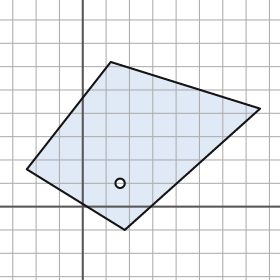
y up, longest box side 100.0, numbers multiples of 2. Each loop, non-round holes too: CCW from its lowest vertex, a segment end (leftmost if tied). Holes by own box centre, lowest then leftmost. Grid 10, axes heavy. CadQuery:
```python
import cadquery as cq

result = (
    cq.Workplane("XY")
    .moveTo(18.0, -10.0)
    .lineTo(76.0, 42.0)
    .lineTo(12.0, 62.0)
    .lineTo(-24.0, 16.0)
    .close()
    .moveTo(16.0, 10.0)
    .circle(2.0)
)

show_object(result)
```